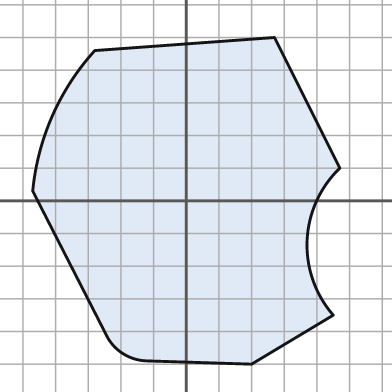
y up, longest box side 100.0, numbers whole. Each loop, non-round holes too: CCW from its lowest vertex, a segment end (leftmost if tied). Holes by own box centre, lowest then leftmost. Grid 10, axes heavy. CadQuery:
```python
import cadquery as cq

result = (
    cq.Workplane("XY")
    .moveTo(20.0, -50.0)
    .lineTo(45.0, -35.0)
    .threePointArc((37.0, -12.0), (47.0, 10.0))
    .lineTo(27.0, 50.0)
    .lineTo(-28.0, 46.0)
    .threePointArc((-41.0, 26.0), (-47.0, 3.0))
    .lineTo(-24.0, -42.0)
    .threePointArc((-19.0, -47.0), (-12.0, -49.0))
    .close()
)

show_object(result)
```